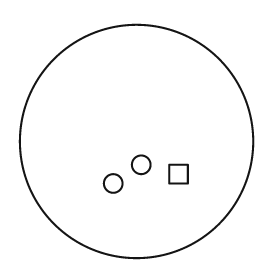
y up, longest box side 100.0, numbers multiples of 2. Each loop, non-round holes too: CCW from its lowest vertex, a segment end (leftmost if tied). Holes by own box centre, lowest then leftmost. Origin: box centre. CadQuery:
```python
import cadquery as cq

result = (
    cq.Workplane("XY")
    .moveTo(0.0, 0.0)
    .circle(50.0)
    .moveTo(-10.0, -18.0)
    .circle(4.0)
    .moveTo(14.0, -18.0)
    .lineTo(22.0, -18.0)
    .lineTo(22.0, -10.0)
    .lineTo(14.0, -10.0)
    .close()
    .moveTo(2.0, -10.0)
    .circle(4.0)
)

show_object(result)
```